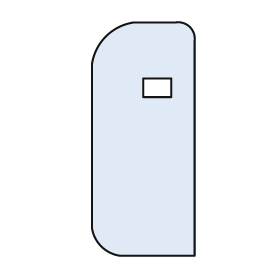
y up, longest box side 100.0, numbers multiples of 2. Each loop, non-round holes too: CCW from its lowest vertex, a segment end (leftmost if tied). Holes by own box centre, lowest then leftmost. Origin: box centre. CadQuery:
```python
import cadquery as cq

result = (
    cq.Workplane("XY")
    .moveTo(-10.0, -50.0)
    .lineTo(22.0, -50.0)
    .lineTo(22.0, 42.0)
    .threePointArc((20.0, 48.0), (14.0, 50.0))
    .lineTo(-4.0, 50.0)
    .threePointArc((-16.0, 44.0), (-22.0, 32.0))
    .lineTo(-22.0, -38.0)
    .threePointArc((-18.0, -46.0), (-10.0, -50.0))
    .close()
    .moveTo(0.0, 18.0)
    .lineTo(12.0, 18.0)
    .lineTo(12.0, 26.0)
    .lineTo(0.0, 26.0)
    .close()
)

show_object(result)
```